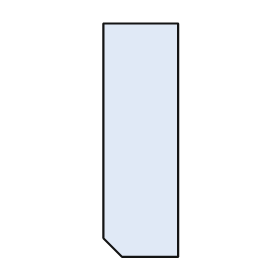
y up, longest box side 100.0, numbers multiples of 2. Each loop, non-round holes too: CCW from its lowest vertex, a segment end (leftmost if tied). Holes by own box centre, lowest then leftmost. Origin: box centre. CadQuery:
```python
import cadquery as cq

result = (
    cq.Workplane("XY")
    .moveTo(-8.0, -50.0)
    .lineTo(16.0, -50.0)
    .lineTo(16.0, 50.0)
    .lineTo(-16.0, 50.0)
    .lineTo(-16.0, -42.0)
    .close()
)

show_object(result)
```